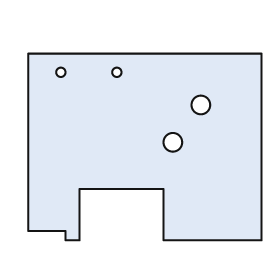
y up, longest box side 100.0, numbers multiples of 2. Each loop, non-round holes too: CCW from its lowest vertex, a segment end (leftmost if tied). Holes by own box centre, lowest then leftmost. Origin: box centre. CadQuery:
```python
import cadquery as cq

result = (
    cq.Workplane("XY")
    .moveTo(-34.0, -40.0)
    .lineTo(-28.0, -40.0)
    .lineTo(-28.0, -18.0)
    .lineTo(8.0, -18.0)
    .lineTo(8.0, -40.0)
    .lineTo(50.0, -40.0)
    .lineTo(50.0, 40.0)
    .lineTo(-50.0, 40.0)
    .lineTo(-50.0, -36.0)
    .lineTo(-34.0, -36.0)
    .close()
    .moveTo(12.0, 2.0)
    .circle(4.0)
    .moveTo(24.0, 18.0)
    .circle(4.0)
    .moveTo(-36.0, 32.0)
    .circle(2.0)
    .moveTo(-12.0, 32.0)
    .circle(2.0)
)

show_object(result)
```